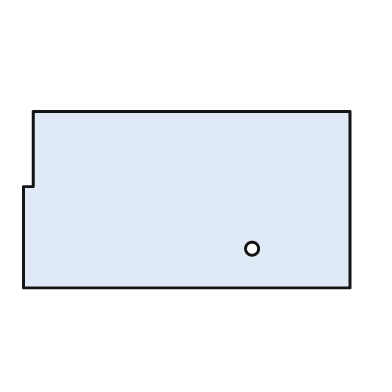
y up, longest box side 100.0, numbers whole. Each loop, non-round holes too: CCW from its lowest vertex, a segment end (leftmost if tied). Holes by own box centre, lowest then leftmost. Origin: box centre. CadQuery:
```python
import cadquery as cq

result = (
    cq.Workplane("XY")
    .moveTo(-50.0, -27.0)
    .lineTo(50.0, -27.0)
    .lineTo(50.0, 27.0)
    .lineTo(-47.0, 27.0)
    .lineTo(-47.0, 4.0)
    .lineTo(-50.0, 4.0)
    .close()
    .moveTo(20.0, -15.0)
    .circle(2.0)
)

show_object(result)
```